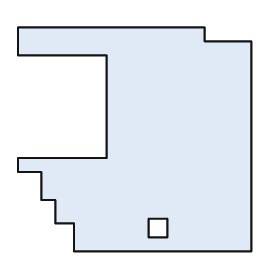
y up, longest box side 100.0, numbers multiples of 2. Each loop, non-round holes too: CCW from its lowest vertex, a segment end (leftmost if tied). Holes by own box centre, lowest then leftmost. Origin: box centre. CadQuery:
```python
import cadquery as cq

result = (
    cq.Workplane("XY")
    .moveTo(-26.0, -48.0)
    .lineTo(50.0, -48.0)
    .lineTo(50.0, 42.0)
    .lineTo(30.0, 42.0)
    .lineTo(30.0, 48.0)
    .lineTo(-50.0, 48.0)
    .lineTo(-50.0, 36.0)
    .lineTo(-12.0, 36.0)
    .lineTo(-12.0, -8.0)
    .lineTo(-50.0, -8.0)
    .lineTo(-50.0, -14.0)
    .lineTo(-40.0, -14.0)
    .lineTo(-40.0, -26.0)
    .lineTo(-34.0, -26.0)
    .lineTo(-34.0, -36.0)
    .lineTo(-26.0, -36.0)
    .close()
    .moveTo(6.0, -42.0)
    .lineTo(14.0, -42.0)
    .lineTo(14.0, -34.0)
    .lineTo(6.0, -34.0)
    .close()
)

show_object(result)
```